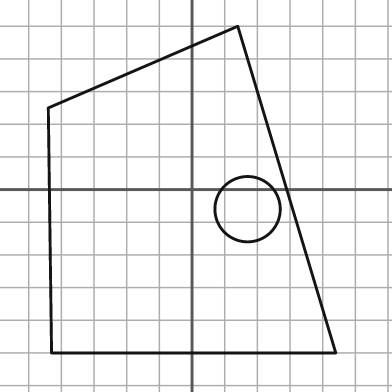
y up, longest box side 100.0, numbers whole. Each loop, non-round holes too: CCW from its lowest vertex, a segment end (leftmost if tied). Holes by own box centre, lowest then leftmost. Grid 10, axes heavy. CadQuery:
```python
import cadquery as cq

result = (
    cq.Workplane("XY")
    .moveTo(-43.0, -50.0)
    .lineTo(44.0, -50.0)
    .lineTo(14.0, 50.0)
    .lineTo(-44.0, 25.0)
    .close()
    .moveTo(17.0, -6.0)
    .circle(10.0)
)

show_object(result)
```